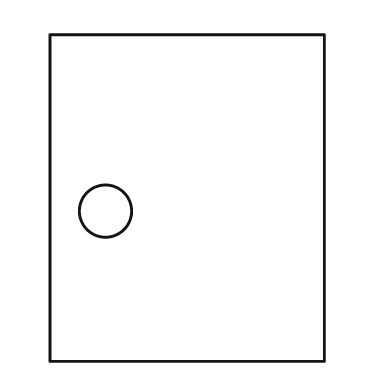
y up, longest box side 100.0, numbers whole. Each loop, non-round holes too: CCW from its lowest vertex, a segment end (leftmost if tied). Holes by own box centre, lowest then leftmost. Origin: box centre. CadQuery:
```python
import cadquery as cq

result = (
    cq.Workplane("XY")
    .moveTo(-42.0, -50.0)
    .lineTo(42.0, -50.0)
    .lineTo(42.0, 50.0)
    .lineTo(-42.0, 50.0)
    .close()
    .moveTo(-25.0, -4.0)
    .circle(8.0)
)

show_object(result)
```